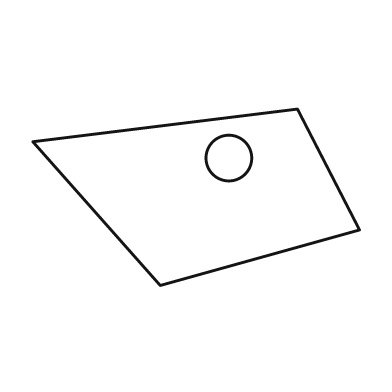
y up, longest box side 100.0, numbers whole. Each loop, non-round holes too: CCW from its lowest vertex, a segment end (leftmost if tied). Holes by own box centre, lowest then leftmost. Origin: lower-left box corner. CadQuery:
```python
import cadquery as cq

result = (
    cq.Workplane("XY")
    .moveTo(39.0, 0.0)
    .lineTo(100.0, 17.0)
    .lineTo(81.0, 54.0)
    .lineTo(0.0, 44.0)
    .close()
    .moveTo(60.0, 39.0)
    .circle(7.0)
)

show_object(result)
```